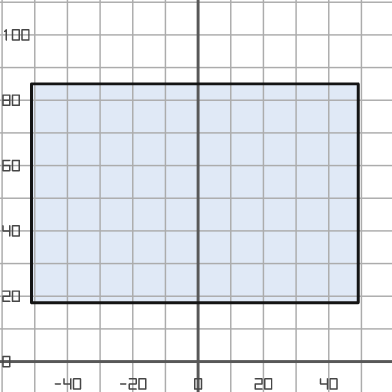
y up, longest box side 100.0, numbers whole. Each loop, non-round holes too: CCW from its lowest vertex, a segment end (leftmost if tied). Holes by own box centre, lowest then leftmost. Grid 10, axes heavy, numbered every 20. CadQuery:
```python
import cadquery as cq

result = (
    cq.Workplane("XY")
    .moveTo(-51.0, 18.0)
    .lineTo(49.0, 18.0)
    .lineTo(49.0, 85.0)
    .lineTo(-51.0, 85.0)
    .close()
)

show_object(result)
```